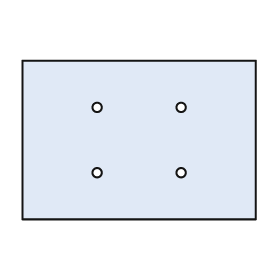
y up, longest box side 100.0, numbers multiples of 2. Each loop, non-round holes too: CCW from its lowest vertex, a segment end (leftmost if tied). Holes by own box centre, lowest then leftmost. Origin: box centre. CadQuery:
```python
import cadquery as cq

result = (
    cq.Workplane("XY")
    .moveTo(-50.0, -34.0)
    .lineTo(50.0, -34.0)
    .lineTo(50.0, 34.0)
    .lineTo(-50.0, 34.0)
    .close()
    .moveTo(-18.0, -14.0)
    .circle(2.0)
    .moveTo(18.0, -14.0)
    .circle(2.0)
    .moveTo(-18.0, 14.0)
    .circle(2.0)
    .moveTo(18.0, 14.0)
    .circle(2.0)
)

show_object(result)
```